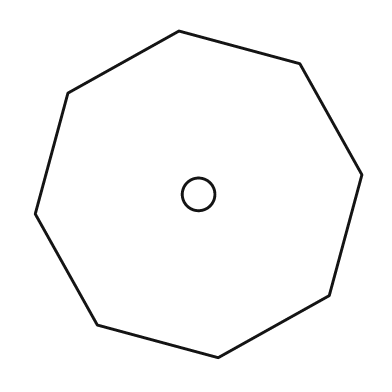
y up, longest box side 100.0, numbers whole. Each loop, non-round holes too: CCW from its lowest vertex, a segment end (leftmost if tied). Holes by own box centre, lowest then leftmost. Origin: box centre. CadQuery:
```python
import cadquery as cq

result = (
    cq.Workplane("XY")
    .moveTo(6.0, -50.0)
    .lineTo(40.0, -31.0)
    .lineTo(50.0, 6.0)
    .lineTo(31.0, 40.0)
    .lineTo(-6.0, 50.0)
    .lineTo(-40.0, 31.0)
    .lineTo(-50.0, -6.0)
    .lineTo(-31.0, -40.0)
    .close()
    .moveTo(0.0, 0.0)
    .circle(5.0)
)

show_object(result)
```